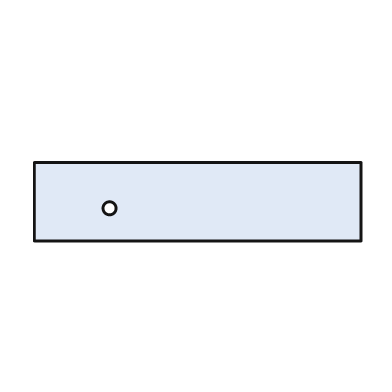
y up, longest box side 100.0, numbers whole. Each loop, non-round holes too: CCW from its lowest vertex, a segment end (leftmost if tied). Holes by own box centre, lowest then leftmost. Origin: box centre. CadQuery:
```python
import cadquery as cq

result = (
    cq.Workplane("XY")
    .moveTo(-50.0, -12.0)
    .lineTo(50.0, -12.0)
    .lineTo(50.0, 12.0)
    .lineTo(-50.0, 12.0)
    .close()
    .moveTo(-27.0, -2.0)
    .circle(2.0)
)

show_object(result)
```